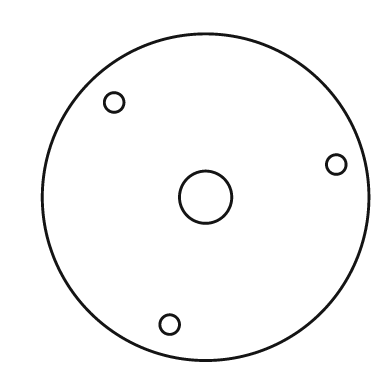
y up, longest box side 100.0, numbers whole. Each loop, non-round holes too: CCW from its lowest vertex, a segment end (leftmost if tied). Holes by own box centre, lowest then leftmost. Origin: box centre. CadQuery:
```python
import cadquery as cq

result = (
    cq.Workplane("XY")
    .moveTo(0.0, 0.0)
    .circle(50.0)
    .moveTo(-11.0, -39.0)
    .circle(3.0)
    .moveTo(0.0, 0.0)
    .circle(8.0)
    .moveTo(40.0, 10.0)
    .circle(3.0)
    .moveTo(-28.0, 29.0)
    .circle(3.0)
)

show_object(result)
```